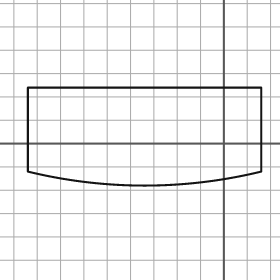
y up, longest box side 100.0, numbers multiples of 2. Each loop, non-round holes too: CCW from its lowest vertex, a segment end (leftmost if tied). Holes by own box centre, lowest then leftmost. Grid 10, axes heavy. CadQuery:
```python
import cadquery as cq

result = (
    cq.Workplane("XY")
    .moveTo(-84.0, -12.0)
    .threePointArc((-34.0, -18.0), (16.0, -12.0))
    .lineTo(16.0, 24.0)
    .lineTo(-84.0, 24.0)
    .close()
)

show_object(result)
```